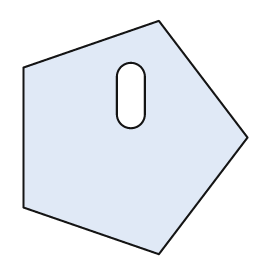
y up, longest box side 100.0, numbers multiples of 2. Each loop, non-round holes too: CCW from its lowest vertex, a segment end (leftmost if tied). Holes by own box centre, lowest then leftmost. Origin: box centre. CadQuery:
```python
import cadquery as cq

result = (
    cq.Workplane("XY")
    .moveTo(10.0, -50.0)
    .lineTo(48.0, 0.0)
    .lineTo(10.0, 50.0)
    .lineTo(-48.0, 30.0)
    .lineTo(-48.0, -30.0)
    .close()
    .moveTo(-8.0, 10.0)
    .threePointArc((-2.0, 4.0), (4.0, 10.0))
    .lineTo(4.0, 26.0)
    .threePointArc((-2.0, 32.0), (-8.0, 26.0))
    .close()
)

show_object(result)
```